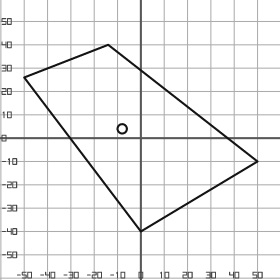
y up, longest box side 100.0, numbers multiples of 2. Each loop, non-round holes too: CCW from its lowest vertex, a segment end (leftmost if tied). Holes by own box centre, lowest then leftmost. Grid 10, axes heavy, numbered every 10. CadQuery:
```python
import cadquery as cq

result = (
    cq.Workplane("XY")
    .moveTo(0.0, -40.0)
    .lineTo(50.0, -10.0)
    .lineTo(-14.0, 40.0)
    .lineTo(-50.0, 26.0)
    .close()
    .moveTo(-8.0, 4.0)
    .circle(2.0)
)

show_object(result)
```